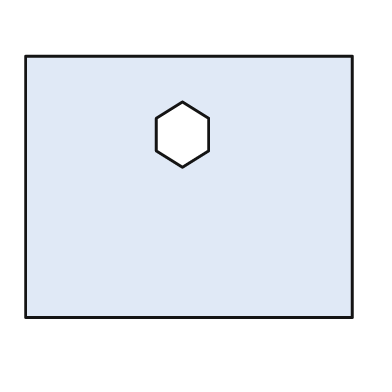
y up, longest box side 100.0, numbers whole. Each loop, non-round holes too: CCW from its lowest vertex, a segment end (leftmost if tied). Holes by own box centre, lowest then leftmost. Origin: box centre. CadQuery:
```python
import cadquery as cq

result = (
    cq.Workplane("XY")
    .moveTo(-50.0, -40.0)
    .lineTo(50.0, -40.0)
    .lineTo(50.0, 40.0)
    .lineTo(-50.0, 40.0)
    .close()
    .moveTo(-2.0, 6.0)
    .lineTo(6.0, 11.0)
    .lineTo(6.0, 21.0)
    .lineTo(-2.0, 26.0)
    .lineTo(-10.0, 21.0)
    .lineTo(-10.0, 11.0)
    .close()
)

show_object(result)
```